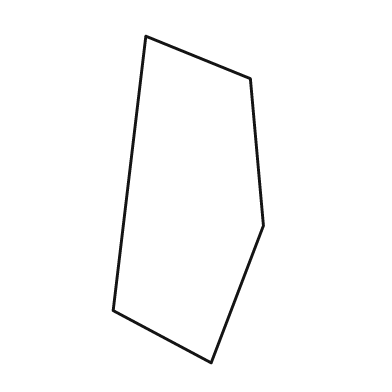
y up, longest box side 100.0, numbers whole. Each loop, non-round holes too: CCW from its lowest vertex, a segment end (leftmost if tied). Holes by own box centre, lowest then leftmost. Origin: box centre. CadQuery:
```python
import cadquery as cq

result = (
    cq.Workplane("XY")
    .moveTo(7.0, -50.0)
    .lineTo(23.0, -8.0)
    .lineTo(19.0, 37.0)
    .lineTo(-13.0, 50.0)
    .lineTo(-23.0, -34.0)
    .close()
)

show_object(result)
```